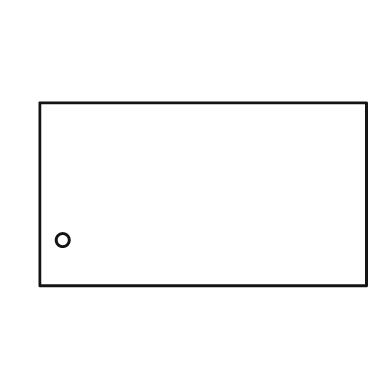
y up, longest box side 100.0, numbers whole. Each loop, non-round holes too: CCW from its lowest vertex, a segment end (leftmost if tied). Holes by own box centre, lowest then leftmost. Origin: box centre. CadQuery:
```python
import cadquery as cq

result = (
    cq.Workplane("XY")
    .moveTo(-50.0, -28.0)
    .lineTo(50.0, -28.0)
    .lineTo(50.0, 28.0)
    .lineTo(-50.0, 28.0)
    .close()
    .moveTo(-43.0, -14.0)
    .circle(2.0)
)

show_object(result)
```